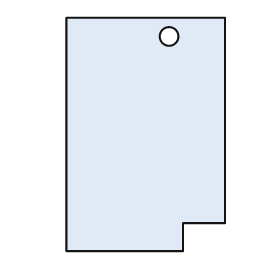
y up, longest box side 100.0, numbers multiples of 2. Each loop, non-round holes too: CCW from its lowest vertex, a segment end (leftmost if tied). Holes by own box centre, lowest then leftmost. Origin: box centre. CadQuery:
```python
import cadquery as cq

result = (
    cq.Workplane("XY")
    .moveTo(-34.0, -50.0)
    .lineTo(16.0, -50.0)
    .lineTo(16.0, -38.0)
    .lineTo(34.0, -38.0)
    .lineTo(34.0, 50.0)
    .lineTo(-34.0, 50.0)
    .close()
    .moveTo(10.0, 42.0)
    .circle(4.0)
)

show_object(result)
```